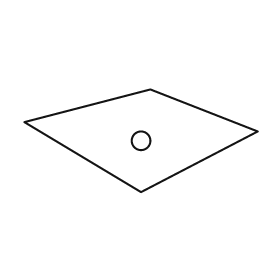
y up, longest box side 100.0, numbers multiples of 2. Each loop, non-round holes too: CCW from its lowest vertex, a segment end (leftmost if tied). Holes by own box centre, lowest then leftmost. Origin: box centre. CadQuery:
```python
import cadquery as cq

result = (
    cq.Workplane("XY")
    .moveTo(0.0, -22.0)
    .lineTo(50.0, 4.0)
    .lineTo(4.0, 22.0)
    .lineTo(-50.0, 8.0)
    .close()
    .moveTo(0.0, 0.0)
    .circle(4.0)
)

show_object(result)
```